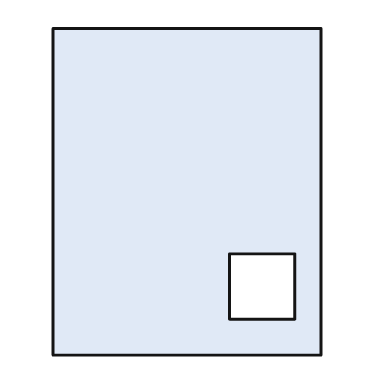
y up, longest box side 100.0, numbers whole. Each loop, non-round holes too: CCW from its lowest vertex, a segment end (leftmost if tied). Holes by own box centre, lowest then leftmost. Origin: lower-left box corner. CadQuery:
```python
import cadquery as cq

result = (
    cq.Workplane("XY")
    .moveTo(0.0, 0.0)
    .lineTo(82.0, 0.0)
    .lineTo(82.0, 100.0)
    .lineTo(0.0, 100.0)
    .close()
    .moveTo(54.0, 11.0)
    .lineTo(74.0, 11.0)
    .lineTo(74.0, 31.0)
    .lineTo(54.0, 31.0)
    .close()
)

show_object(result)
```